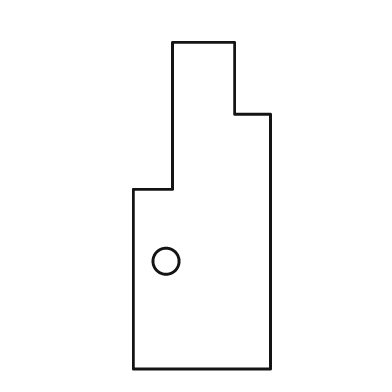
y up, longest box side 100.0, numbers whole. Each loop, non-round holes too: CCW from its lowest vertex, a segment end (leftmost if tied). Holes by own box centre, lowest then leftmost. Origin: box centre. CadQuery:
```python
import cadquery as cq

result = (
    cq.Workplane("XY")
    .moveTo(-21.0, -50.0)
    .lineTo(21.0, -50.0)
    .lineTo(21.0, 28.0)
    .lineTo(10.0, 28.0)
    .lineTo(10.0, 50.0)
    .lineTo(-9.0, 50.0)
    .lineTo(-9.0, 5.0)
    .lineTo(-21.0, 5.0)
    .close()
    .moveTo(-11.0, -17.0)
    .circle(4.0)
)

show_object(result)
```